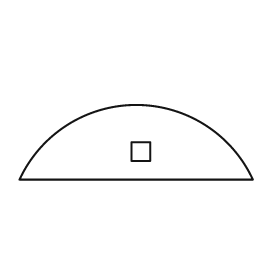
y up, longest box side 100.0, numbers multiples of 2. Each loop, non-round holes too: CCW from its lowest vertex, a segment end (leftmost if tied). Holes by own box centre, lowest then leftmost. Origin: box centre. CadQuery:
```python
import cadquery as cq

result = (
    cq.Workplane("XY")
    .moveTo(-50.0, -16.0)
    .lineTo(50.0, -16.0)
    .threePointArc((0.0, 16.0), (-50.0, -16.0))
    .close()
    .moveTo(-2.0, -8.0)
    .lineTo(6.0, -8.0)
    .lineTo(6.0, 0.0)
    .lineTo(-2.0, 0.0)
    .close()
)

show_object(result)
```